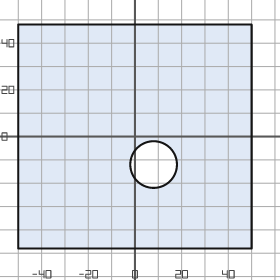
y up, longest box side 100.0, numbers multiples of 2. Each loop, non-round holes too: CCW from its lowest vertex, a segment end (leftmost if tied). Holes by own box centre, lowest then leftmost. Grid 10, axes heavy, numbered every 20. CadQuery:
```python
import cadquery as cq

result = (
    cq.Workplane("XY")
    .moveTo(-50.0, -48.0)
    .lineTo(50.0, -48.0)
    .lineTo(50.0, 48.0)
    .lineTo(-50.0, 48.0)
    .close()
    .moveTo(8.0, -12.0)
    .circle(10.0)
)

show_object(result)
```